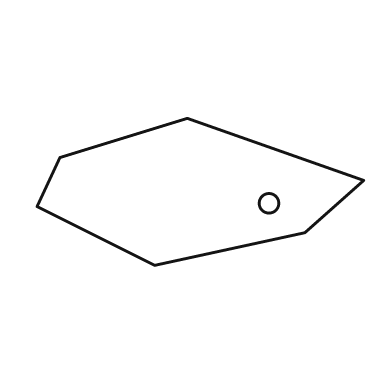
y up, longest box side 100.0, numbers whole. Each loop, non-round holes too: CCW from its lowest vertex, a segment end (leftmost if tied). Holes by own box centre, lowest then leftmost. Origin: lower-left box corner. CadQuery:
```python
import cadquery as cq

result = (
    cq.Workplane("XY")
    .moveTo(36.0, 0.0)
    .lineTo(82.0, 10.0)
    .lineTo(100.0, 26.0)
    .lineTo(46.0, 45.0)
    .lineTo(7.0, 33.0)
    .lineTo(0.0, 18.0)
    .close()
    .moveTo(71.0, 19.0)
    .circle(3.0)
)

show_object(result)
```